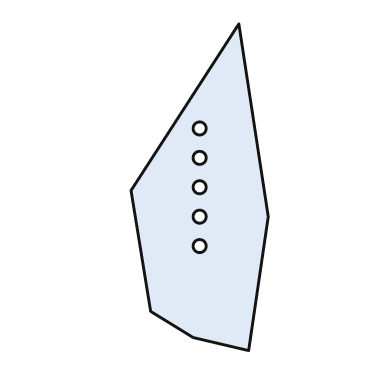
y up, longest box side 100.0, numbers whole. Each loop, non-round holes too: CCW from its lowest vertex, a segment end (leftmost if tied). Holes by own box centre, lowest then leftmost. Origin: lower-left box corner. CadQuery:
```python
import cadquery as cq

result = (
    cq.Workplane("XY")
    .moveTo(36.0, 0.0)
    .lineTo(42.0, 41.0)
    .lineTo(33.0, 100.0)
    .lineTo(0.0, 49.0)
    .lineTo(6.0, 12.0)
    .lineTo(19.0, 4.0)
    .close()
    .moveTo(21.0, 32.0)
    .circle(2.0)
    .moveTo(21.0, 41.0)
    .circle(2.0)
    .moveTo(21.0, 50.0)
    .circle(2.0)
    .moveTo(21.0, 59.0)
    .circle(2.0)
    .moveTo(21.0, 68.0)
    .circle(2.0)
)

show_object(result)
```